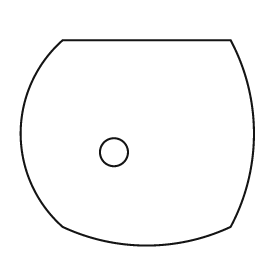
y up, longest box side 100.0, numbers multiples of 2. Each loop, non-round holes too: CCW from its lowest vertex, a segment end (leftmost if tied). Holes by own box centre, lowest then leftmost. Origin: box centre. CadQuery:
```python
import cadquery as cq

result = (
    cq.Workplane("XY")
    .moveTo(-32.0, -36.0)
    .threePointArc((4.0, -44.0), (40.0, -36.0))
    .threePointArc((50.0, 4.0), (40.0, 44.0))
    .lineTo(-32.0, 44.0)
    .threePointArc((-50.0, 4.0), (-32.0, -36.0))
    .close()
    .moveTo(-10.0, -4.0)
    .circle(6.0)
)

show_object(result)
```